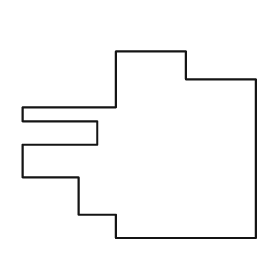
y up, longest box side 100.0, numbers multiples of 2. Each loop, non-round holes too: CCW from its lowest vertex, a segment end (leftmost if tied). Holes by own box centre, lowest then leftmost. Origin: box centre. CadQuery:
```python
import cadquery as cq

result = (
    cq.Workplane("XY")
    .moveTo(-10.0, -40.0)
    .lineTo(50.0, -40.0)
    .lineTo(50.0, 28.0)
    .lineTo(20.0, 28.0)
    .lineTo(20.0, 40.0)
    .lineTo(-10.0, 40.0)
    .lineTo(-10.0, 16.0)
    .lineTo(-50.0, 16.0)
    .lineTo(-50.0, 10.0)
    .lineTo(-18.0, 10.0)
    .lineTo(-18.0, 0.0)
    .lineTo(-50.0, 0.0)
    .lineTo(-50.0, -14.0)
    .lineTo(-26.0, -14.0)
    .lineTo(-26.0, -30.0)
    .lineTo(-10.0, -30.0)
    .close()
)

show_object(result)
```